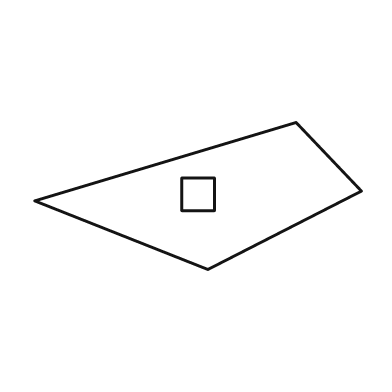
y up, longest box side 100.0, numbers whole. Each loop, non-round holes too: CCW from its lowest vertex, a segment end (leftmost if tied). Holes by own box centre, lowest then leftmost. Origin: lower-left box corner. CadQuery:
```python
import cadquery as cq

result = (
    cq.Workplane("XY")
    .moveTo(53.0, 0.0)
    .lineTo(100.0, 24.0)
    .lineTo(80.0, 45.0)
    .lineTo(0.0, 21.0)
    .close()
    .moveTo(45.0, 18.0)
    .lineTo(55.0, 18.0)
    .lineTo(55.0, 28.0)
    .lineTo(45.0, 28.0)
    .close()
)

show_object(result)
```